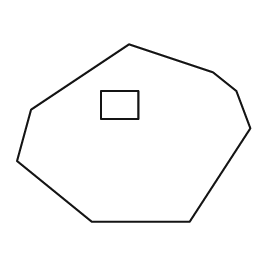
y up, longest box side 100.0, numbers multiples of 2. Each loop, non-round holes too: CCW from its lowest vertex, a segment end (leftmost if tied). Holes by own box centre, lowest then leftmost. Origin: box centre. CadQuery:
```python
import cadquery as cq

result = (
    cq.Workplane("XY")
    .moveTo(-18.0, -38.0)
    .lineTo(24.0, -38.0)
    .lineTo(50.0, 2.0)
    .lineTo(44.0, 18.0)
    .lineTo(34.0, 26.0)
    .lineTo(-2.0, 38.0)
    .lineTo(-44.0, 10.0)
    .lineTo(-50.0, -12.0)
    .close()
    .moveTo(-14.0, 6.0)
    .lineTo(2.0, 6.0)
    .lineTo(2.0, 18.0)
    .lineTo(-14.0, 18.0)
    .close()
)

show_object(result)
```